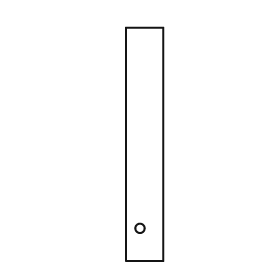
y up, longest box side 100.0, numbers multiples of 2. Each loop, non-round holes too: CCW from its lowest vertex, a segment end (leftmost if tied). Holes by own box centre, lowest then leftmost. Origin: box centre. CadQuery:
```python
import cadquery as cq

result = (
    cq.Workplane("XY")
    .moveTo(-8.0, -50.0)
    .lineTo(8.0, -50.0)
    .lineTo(8.0, 50.0)
    .lineTo(-8.0, 50.0)
    .close()
    .moveTo(-2.0, -36.0)
    .circle(2.0)
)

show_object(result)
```